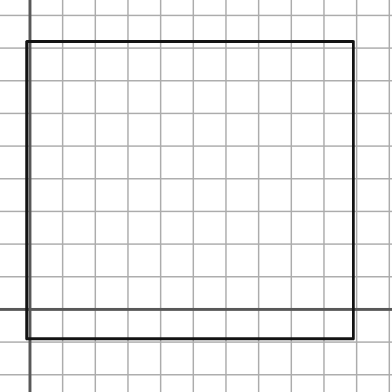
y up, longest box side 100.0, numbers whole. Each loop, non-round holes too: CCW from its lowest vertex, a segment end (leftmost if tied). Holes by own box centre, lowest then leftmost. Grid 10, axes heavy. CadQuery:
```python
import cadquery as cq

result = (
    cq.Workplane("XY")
    .moveTo(-1.0, -9.0)
    .lineTo(99.0, -9.0)
    .lineTo(99.0, 82.0)
    .lineTo(-1.0, 82.0)
    .close()
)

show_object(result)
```